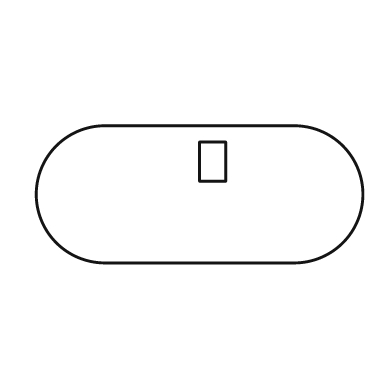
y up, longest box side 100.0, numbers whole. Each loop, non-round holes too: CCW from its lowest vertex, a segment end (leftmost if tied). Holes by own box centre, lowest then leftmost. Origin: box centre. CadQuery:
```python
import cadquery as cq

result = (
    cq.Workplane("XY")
    .moveTo(-29.0, -21.0)
    .lineTo(29.0, -21.0)
    .threePointArc((50.0, 0.0), (29.0, 21.0))
    .lineTo(-29.0, 21.0)
    .threePointArc((-50.0, 0.0), (-29.0, -21.0))
    .close()
    .moveTo(0.0, 4.0)
    .lineTo(8.0, 4.0)
    .lineTo(8.0, 16.0)
    .lineTo(0.0, 16.0)
    .close()
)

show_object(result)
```